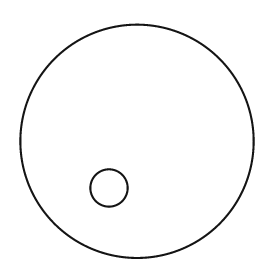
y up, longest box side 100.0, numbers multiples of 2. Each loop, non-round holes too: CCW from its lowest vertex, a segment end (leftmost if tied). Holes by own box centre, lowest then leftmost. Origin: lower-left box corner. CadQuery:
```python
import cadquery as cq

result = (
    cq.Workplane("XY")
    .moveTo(50.0, 50.0)
    .circle(50.0)
    .moveTo(38.0, 30.0)
    .circle(8.0)
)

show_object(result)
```